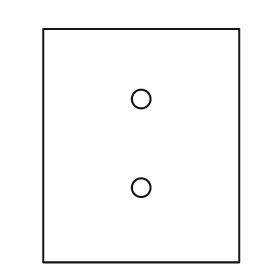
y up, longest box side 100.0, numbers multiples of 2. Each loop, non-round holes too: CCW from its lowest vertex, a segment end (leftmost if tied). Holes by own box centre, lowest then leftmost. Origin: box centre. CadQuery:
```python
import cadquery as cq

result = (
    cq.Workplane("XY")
    .moveTo(-42.0, -50.0)
    .lineTo(42.0, -50.0)
    .lineTo(42.0, 50.0)
    .lineTo(-42.0, 50.0)
    .close()
    .moveTo(0.0, -18.0)
    .circle(4.0)
    .moveTo(0.0, 20.0)
    .circle(4.0)
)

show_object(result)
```